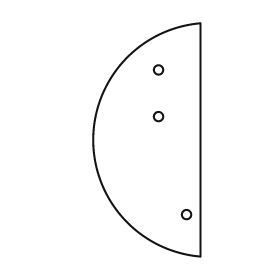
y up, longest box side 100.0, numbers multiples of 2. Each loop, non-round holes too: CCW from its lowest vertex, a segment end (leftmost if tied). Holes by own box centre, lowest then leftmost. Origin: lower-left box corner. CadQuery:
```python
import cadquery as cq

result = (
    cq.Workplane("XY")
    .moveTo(46.0, 0.0)
    .lineTo(46.0, 100.0)
    .threePointArc((0.0, 50.0), (46.0, 0.0))
    .close()
    .moveTo(40.0, 18.0)
    .circle(2.0)
    .moveTo(28.0, 60.0)
    .circle(2.0)
    .moveTo(28.0, 80.0)
    .circle(2.0)
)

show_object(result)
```